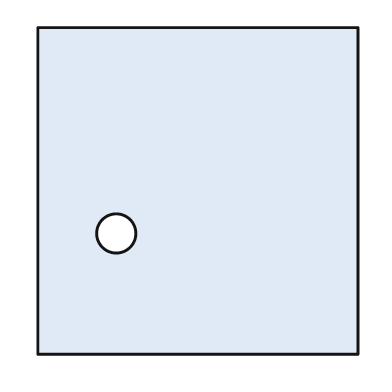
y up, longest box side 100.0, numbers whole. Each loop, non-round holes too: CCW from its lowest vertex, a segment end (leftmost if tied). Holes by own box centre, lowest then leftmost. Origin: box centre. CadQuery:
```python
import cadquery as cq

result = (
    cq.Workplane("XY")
    .moveTo(-49.0, -50.0)
    .lineTo(49.0, -50.0)
    .lineTo(49.0, 50.0)
    .lineTo(-49.0, 50.0)
    .close()
    .moveTo(-25.0, -13.0)
    .circle(6.0)
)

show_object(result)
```